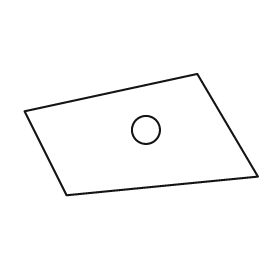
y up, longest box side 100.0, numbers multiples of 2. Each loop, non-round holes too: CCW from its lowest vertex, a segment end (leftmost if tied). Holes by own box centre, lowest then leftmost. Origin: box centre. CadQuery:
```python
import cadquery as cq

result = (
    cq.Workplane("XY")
    .moveTo(-32.0, -26.0)
    .lineTo(50.0, -18.0)
    .lineTo(24.0, 26.0)
    .lineTo(-50.0, 10.0)
    .close()
    .moveTo(2.0, 2.0)
    .circle(6.0)
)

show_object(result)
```